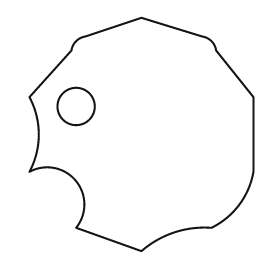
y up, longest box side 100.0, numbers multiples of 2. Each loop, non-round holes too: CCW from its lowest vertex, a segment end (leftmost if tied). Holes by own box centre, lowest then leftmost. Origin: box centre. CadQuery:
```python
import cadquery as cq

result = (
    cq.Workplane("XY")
    .moveTo(0.0, -50.0)
    .threePointArc((14.0, -42.0), (30.0, -40.0))
    .threePointArc((42.0, -30.0), (48.0, -16.0))
    .lineTo(48.0, 16.0)
    .lineTo(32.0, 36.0)
    .threePointArc((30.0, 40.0), (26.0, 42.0))
    .lineTo(0.0, 50.0)
    .lineTo(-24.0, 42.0)
    .threePointArc((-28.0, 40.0), (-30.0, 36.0))
    .lineTo(-48.0, 16.0)
    .threePointArc((-44.0, 0.0), (-48.0, -16.0))
    .threePointArc((-28.0, -20.0), (-28.0, -40.0))
    .close()
    .moveTo(-28.0, 12.0)
    .circle(8.0)
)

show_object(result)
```